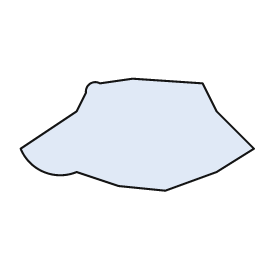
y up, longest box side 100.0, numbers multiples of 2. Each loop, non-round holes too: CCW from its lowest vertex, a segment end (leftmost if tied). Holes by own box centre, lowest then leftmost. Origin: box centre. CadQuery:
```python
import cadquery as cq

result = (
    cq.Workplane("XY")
    .moveTo(12.0, -24.0)
    .lineTo(34.0, -16.0)
    .lineTo(50.0, -6.0)
    .lineTo(34.0, 10.0)
    .lineTo(28.0, 22.0)
    .lineTo(-2.0, 24.0)
    .lineTo(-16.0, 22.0)
    .threePointArc((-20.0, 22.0), (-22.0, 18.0))
    .lineTo(-26.0, 10.0)
    .lineTo(-50.0, -6.0)
    .threePointArc((-40.0, -16.0), (-26.0, -16.0))
    .lineTo(-8.0, -22.0)
    .close()
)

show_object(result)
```